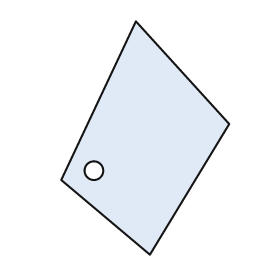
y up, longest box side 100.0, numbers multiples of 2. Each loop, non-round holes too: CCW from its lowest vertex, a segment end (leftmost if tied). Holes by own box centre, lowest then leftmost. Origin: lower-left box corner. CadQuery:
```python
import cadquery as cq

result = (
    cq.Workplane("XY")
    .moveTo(38.0, 0.0)
    .lineTo(72.0, 56.0)
    .lineTo(32.0, 100.0)
    .lineTo(0.0, 32.0)
    .close()
    .moveTo(14.0, 36.0)
    .circle(4.0)
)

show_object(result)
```